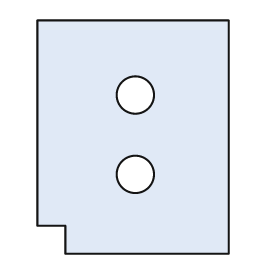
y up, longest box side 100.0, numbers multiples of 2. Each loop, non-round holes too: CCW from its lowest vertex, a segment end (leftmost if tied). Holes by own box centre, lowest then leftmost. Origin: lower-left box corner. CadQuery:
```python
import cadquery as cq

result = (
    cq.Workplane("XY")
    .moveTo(12.0, 0.0)
    .lineTo(82.0, 0.0)
    .lineTo(82.0, 100.0)
    .lineTo(0.0, 100.0)
    .lineTo(0.0, 12.0)
    .lineTo(12.0, 12.0)
    .close()
    .moveTo(42.0, 34.0)
    .circle(8.0)
    .moveTo(42.0, 68.0)
    .circle(8.0)
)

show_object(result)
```